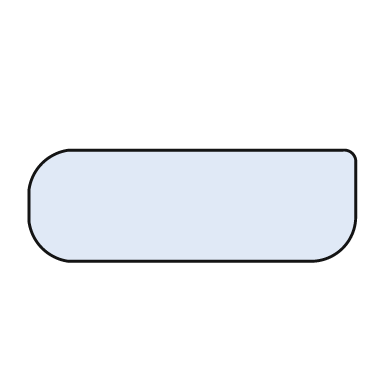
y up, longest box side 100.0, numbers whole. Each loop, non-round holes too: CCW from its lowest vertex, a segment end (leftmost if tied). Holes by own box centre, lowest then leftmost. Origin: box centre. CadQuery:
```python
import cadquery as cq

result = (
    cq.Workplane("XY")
    .moveTo(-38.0, -17.0)
    .lineTo(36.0, -17.0)
    .threePointArc((46.0, -13.0), (50.0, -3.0))
    .lineTo(50.0, 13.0)
    .threePointArc((49.0, 16.0), (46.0, 17.0))
    .lineTo(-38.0, 17.0)
    .threePointArc((-46.0, 13.0), (-50.0, 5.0))
    .lineTo(-50.0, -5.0)
    .threePointArc((-46.0, -13.0), (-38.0, -17.0))
    .close()
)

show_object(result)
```